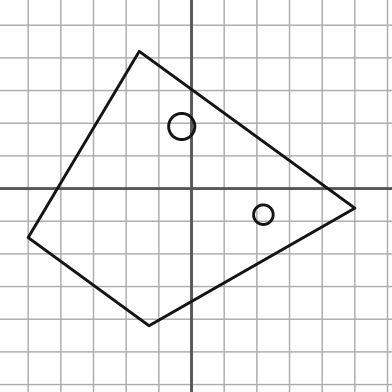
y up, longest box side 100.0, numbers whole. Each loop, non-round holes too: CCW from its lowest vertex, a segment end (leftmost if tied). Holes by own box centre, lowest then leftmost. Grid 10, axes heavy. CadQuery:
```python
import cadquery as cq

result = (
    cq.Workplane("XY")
    .moveTo(-13.0, -42.0)
    .lineTo(50.0, -6.0)
    .lineTo(-16.0, 42.0)
    .lineTo(-50.0, -15.0)
    .close()
    .moveTo(22.0, -8.0)
    .circle(3.0)
    .moveTo(-3.0, 19.0)
    .circle(4.0)
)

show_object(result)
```